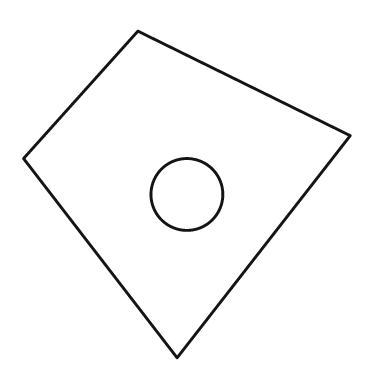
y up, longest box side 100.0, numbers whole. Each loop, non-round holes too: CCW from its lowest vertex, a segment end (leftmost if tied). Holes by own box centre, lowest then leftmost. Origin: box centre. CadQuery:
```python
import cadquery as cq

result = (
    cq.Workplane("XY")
    .moveTo(-3.0, -50.0)
    .lineTo(50.0, 18.0)
    .lineTo(-15.0, 50.0)
    .lineTo(-50.0, 11.0)
    .close()
    .moveTo(0.0, 0.0)
    .circle(11.0)
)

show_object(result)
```